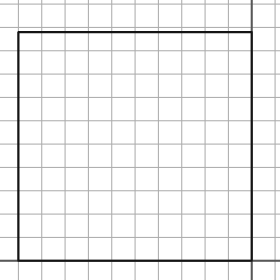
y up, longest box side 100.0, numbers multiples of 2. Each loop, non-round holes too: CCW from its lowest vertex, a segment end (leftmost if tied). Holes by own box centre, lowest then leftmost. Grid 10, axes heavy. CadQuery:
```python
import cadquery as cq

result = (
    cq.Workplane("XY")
    .moveTo(-100.0, 0.0)
    .lineTo(0.0, 0.0)
    .lineTo(0.0, 98.0)
    .lineTo(-100.0, 98.0)
    .close()
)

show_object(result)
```